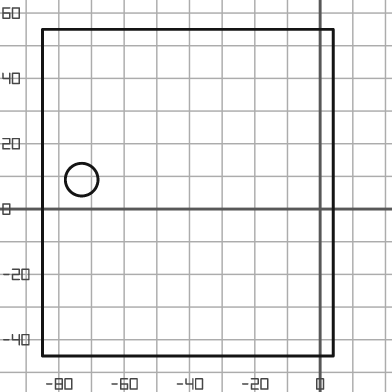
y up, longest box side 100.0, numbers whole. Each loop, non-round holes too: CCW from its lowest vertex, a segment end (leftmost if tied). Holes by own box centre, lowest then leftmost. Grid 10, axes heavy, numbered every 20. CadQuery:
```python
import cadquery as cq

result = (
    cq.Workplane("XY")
    .moveTo(-85.0, -45.0)
    .lineTo(4.0, -45.0)
    .lineTo(4.0, 55.0)
    .lineTo(-85.0, 55.0)
    .close()
    .moveTo(-73.0, 9.0)
    .circle(5.0)
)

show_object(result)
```